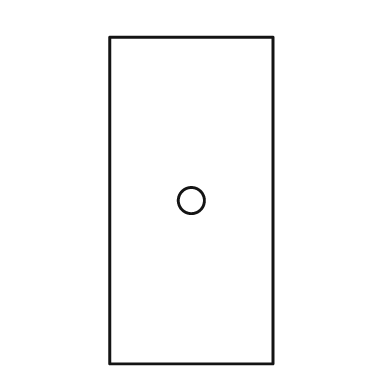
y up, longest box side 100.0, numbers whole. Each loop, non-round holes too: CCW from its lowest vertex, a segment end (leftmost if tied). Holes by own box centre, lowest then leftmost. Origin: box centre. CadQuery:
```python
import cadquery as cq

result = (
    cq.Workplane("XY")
    .moveTo(-25.0, -50.0)
    .lineTo(25.0, -50.0)
    .lineTo(25.0, 50.0)
    .lineTo(-25.0, 50.0)
    .close()
    .moveTo(0.0, 0.0)
    .circle(4.0)
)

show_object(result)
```